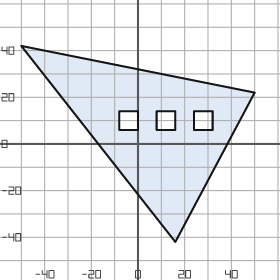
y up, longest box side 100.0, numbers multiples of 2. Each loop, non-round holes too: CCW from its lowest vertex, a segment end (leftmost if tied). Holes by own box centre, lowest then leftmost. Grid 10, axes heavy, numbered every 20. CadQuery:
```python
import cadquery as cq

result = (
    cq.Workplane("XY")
    .moveTo(16.0, -42.0)
    .lineTo(50.0, 22.0)
    .lineTo(-50.0, 42.0)
    .close()
    .moveTo(-8.0, 6.0)
    .lineTo(0.0, 6.0)
    .lineTo(0.0, 14.0)
    .lineTo(-8.0, 14.0)
    .close()
    .moveTo(8.0, 6.0)
    .lineTo(16.0, 6.0)
    .lineTo(16.0, 14.0)
    .lineTo(8.0, 14.0)
    .close()
    .moveTo(24.0, 6.0)
    .lineTo(32.0, 6.0)
    .lineTo(32.0, 14.0)
    .lineTo(24.0, 14.0)
    .close()
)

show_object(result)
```